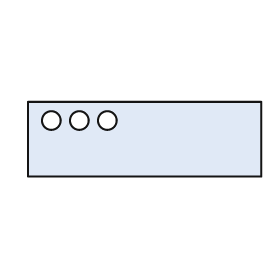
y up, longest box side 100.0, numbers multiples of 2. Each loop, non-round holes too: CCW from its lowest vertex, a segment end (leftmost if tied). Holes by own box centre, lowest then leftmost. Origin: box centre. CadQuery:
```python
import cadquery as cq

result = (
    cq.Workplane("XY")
    .moveTo(-50.0, -16.0)
    .lineTo(50.0, -16.0)
    .lineTo(50.0, 16.0)
    .lineTo(-50.0, 16.0)
    .close()
    .moveTo(-40.0, 8.0)
    .circle(4.0)
    .moveTo(-28.0, 8.0)
    .circle(4.0)
    .moveTo(-16.0, 8.0)
    .circle(4.0)
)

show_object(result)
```